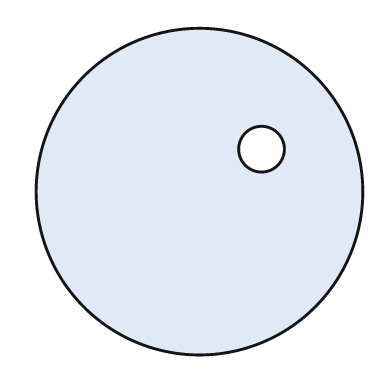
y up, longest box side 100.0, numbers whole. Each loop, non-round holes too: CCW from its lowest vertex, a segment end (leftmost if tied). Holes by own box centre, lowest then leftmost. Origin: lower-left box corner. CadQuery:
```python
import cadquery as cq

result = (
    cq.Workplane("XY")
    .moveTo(50.0, 50.0)
    .circle(50.0)
    .moveTo(69.0, 63.0)
    .circle(7.0)
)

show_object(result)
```